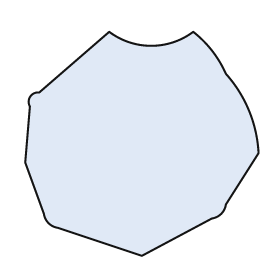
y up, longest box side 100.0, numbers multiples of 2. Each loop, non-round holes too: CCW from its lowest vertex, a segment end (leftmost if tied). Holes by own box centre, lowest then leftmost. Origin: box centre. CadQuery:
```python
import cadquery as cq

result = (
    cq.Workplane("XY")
    .moveTo(0.0, -48.0)
    .lineTo(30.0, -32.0)
    .threePointArc((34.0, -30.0), (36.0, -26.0))
    .lineTo(50.0, -4.0)
    .threePointArc((46.0, 14.0), (36.0, 30.0))
    .threePointArc((30.0, 40.0), (22.0, 48.0))
    .threePointArc((4.0, 42.0), (-14.0, 48.0))
    .lineTo(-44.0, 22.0)
    .threePointArc((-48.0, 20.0), (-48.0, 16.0))
    .lineTo(-50.0, -8.0)
    .lineTo(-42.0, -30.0)
    .threePointArc((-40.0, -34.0), (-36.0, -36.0))
    .close()
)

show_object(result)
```